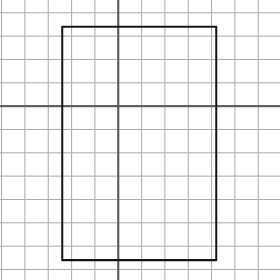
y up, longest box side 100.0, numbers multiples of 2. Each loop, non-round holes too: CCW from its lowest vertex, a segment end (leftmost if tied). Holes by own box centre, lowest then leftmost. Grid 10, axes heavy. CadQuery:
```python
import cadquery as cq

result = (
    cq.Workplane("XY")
    .moveTo(-24.0, -66.0)
    .lineTo(42.0, -66.0)
    .lineTo(42.0, 34.0)
    .lineTo(-24.0, 34.0)
    .close()
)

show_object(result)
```